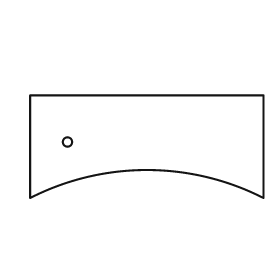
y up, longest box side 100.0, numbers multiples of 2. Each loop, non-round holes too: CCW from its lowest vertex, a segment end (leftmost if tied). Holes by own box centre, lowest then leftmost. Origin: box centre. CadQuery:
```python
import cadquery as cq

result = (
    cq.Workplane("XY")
    .moveTo(-50.0, -22.0)
    .threePointArc((0.0, -10.0), (50.0, -22.0))
    .lineTo(50.0, 22.0)
    .lineTo(-50.0, 22.0)
    .close()
    .moveTo(-34.0, 2.0)
    .circle(2.0)
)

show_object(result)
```